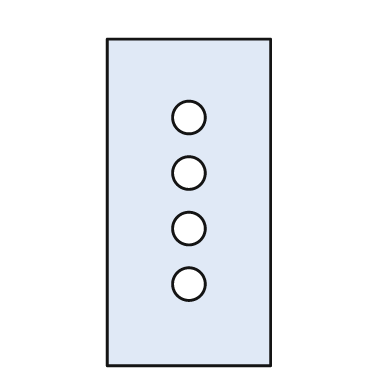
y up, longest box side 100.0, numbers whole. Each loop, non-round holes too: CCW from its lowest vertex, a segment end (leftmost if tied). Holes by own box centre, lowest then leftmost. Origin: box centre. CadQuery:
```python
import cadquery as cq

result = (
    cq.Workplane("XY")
    .moveTo(-25.0, -50.0)
    .lineTo(25.0, -50.0)
    .lineTo(25.0, 50.0)
    .lineTo(-25.0, 50.0)
    .close()
    .moveTo(0.0, -25.0)
    .circle(5.0)
    .moveTo(0.0, -8.0)
    .circle(5.0)
    .moveTo(0.0, 9.0)
    .circle(5.0)
    .moveTo(0.0, 26.0)
    .circle(5.0)
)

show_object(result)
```